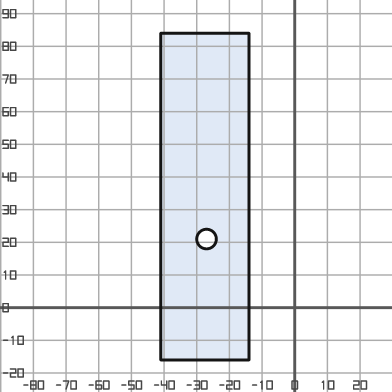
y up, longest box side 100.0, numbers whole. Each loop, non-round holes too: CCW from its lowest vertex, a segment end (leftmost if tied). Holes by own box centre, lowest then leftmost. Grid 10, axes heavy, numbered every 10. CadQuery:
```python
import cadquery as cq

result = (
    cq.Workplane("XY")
    .moveTo(-41.0, -16.0)
    .lineTo(-14.0, -16.0)
    .lineTo(-14.0, 84.0)
    .lineTo(-41.0, 84.0)
    .close()
    .moveTo(-27.0, 21.0)
    .circle(3.0)
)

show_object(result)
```